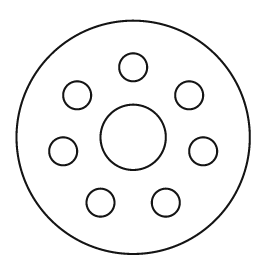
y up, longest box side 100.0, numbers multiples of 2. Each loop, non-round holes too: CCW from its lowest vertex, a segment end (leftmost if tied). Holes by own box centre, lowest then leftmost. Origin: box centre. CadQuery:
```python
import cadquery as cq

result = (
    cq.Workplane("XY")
    .moveTo(0.0, 0.0)
    .circle(50.0)
    .moveTo(-14.0, -28.0)
    .circle(6.0)
    .moveTo(14.0, -28.0)
    .circle(6.0)
    .moveTo(-30.0, -6.0)
    .circle(6.0)
    .moveTo(30.0, -6.0)
    .circle(6.0)
    .moveTo(0.0, 0.0)
    .circle(14.0)
    .moveTo(-24.0, 18.0)
    .circle(6.0)
    .moveTo(24.0, 18.0)
    .circle(6.0)
    .moveTo(0.0, 30.0)
    .circle(6.0)
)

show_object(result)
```